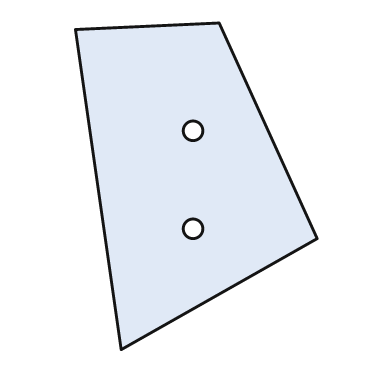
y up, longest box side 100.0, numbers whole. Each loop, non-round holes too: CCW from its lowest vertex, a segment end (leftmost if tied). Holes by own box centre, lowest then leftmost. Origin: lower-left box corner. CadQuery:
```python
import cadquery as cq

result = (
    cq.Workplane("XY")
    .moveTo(14.0, 0.0)
    .lineTo(74.0, 34.0)
    .lineTo(44.0, 100.0)
    .lineTo(0.0, 98.0)
    .close()
    .moveTo(36.0, 37.0)
    .circle(3.0)
    .moveTo(36.0, 67.0)
    .circle(3.0)
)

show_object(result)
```